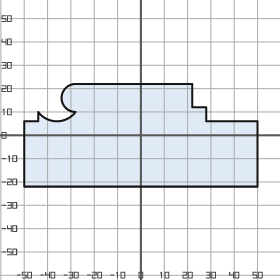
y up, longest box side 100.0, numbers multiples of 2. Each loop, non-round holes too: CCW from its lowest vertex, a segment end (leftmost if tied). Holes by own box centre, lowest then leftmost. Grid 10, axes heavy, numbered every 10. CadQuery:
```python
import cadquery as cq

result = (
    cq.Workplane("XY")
    .moveTo(-50.0, -22.0)
    .lineTo(50.0, -22.0)
    .lineTo(50.0, 6.0)
    .lineTo(28.0, 6.0)
    .lineTo(28.0, 12.0)
    .lineTo(22.0, 12.0)
    .lineTo(22.0, 22.0)
    .lineTo(-28.0, 22.0)
    .threePointArc((-34.0, 16.0), (-28.0, 10.0))
    .threePointArc((-36.0, 6.0), (-44.0, 10.0))
    .lineTo(-44.0, 6.0)
    .lineTo(-50.0, 6.0)
    .close()
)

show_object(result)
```